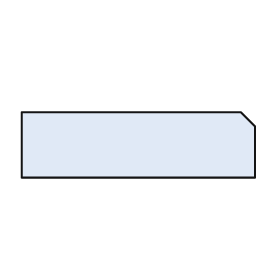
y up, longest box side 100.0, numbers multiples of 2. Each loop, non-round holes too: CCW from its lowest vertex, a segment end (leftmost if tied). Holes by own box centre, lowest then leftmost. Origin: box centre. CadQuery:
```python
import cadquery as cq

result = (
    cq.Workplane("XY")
    .moveTo(-50.0, -14.0)
    .lineTo(50.0, -14.0)
    .lineTo(50.0, 8.0)
    .lineTo(44.0, 14.0)
    .lineTo(-50.0, 14.0)
    .close()
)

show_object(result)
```